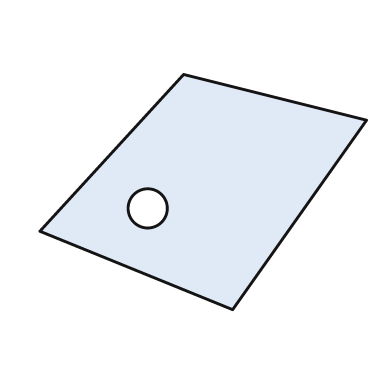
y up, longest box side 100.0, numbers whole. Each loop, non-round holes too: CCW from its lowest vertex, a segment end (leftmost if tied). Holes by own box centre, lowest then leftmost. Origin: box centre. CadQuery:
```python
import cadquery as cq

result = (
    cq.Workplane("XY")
    .moveTo(9.0, -36.0)
    .lineTo(50.0, 22.0)
    .lineTo(-6.0, 36.0)
    .lineTo(-50.0, -12.0)
    .close()
    .moveTo(-17.0, -5.0)
    .circle(6.0)
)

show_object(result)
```